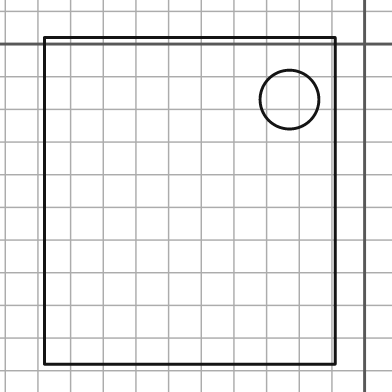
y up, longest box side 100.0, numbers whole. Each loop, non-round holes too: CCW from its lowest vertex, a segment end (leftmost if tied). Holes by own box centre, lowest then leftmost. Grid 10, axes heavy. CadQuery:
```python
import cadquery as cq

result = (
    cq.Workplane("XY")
    .moveTo(-98.0, -98.0)
    .lineTo(-9.0, -98.0)
    .lineTo(-9.0, 2.0)
    .lineTo(-98.0, 2.0)
    .close()
    .moveTo(-23.0, -17.0)
    .circle(9.0)
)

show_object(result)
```